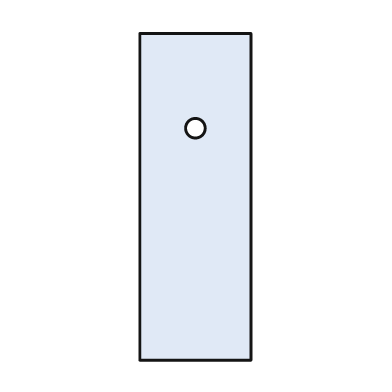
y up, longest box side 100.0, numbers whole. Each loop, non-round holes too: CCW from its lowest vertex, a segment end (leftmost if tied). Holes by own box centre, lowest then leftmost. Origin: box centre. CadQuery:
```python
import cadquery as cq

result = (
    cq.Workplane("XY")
    .moveTo(-17.0, -50.0)
    .lineTo(17.0, -50.0)
    .lineTo(17.0, 50.0)
    .lineTo(-17.0, 50.0)
    .close()
    .moveTo(0.0, 21.0)
    .circle(3.0)
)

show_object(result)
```